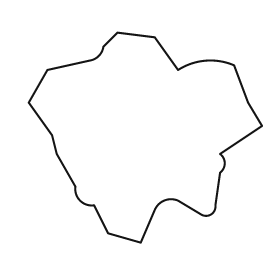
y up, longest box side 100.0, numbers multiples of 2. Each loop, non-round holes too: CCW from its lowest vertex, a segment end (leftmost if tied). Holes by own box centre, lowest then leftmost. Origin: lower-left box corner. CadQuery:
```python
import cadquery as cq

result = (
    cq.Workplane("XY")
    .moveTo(48.0, 0.0)
    .lineTo(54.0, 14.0)
    .threePointArc((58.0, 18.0), (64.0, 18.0))
    .lineTo(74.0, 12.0)
    .threePointArc((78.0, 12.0), (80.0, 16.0))
    .lineTo(82.0, 30.0)
    .threePointArc((84.0, 34.0), (82.0, 38.0))
    .lineTo(100.0, 50.0)
    .lineTo(94.0, 60.0)
    .lineTo(88.0, 76.0)
    .threePointArc((76.0, 78.0), (64.0, 74.0))
    .lineTo(54.0, 88.0)
    .lineTo(38.0, 90.0)
    .lineTo(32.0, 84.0)
    .threePointArc((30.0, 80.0), (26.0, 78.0))
    .lineTo(8.0, 74.0)
    .lineTo(0.0, 60.0)
    .lineTo(10.0, 46.0)
    .lineTo(12.0, 38.0)
    .lineTo(20.0, 24.0)
    .threePointArc((22.0, 18.0), (28.0, 16.0))
    .lineTo(34.0, 4.0)
    .close()
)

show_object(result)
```